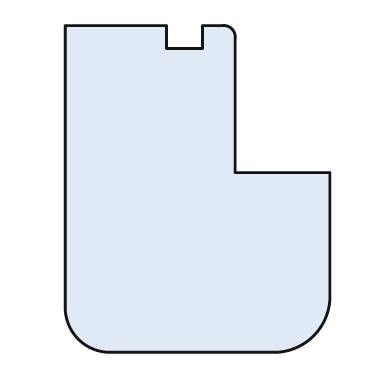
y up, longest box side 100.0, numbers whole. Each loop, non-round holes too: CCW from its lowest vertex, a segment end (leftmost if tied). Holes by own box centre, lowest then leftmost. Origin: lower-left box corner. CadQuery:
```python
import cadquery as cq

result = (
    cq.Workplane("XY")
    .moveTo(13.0, 0.0)
    .lineTo(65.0, 0.0)
    .threePointArc((76.0, 5.0), (81.0, 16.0))
    .lineTo(81.0, 55.0)
    .lineTo(52.0, 55.0)
    .lineTo(52.0, 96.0)
    .threePointArc((51.0, 99.0), (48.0, 100.0))
    .lineTo(42.0, 100.0)
    .lineTo(42.0, 93.0)
    .lineTo(31.0, 93.0)
    .lineTo(31.0, 100.0)
    .lineTo(0.0, 100.0)
    .lineTo(0.0, 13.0)
    .threePointArc((4.0, 4.0), (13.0, 0.0))
    .close()
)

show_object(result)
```